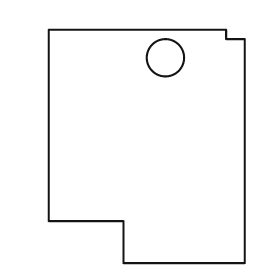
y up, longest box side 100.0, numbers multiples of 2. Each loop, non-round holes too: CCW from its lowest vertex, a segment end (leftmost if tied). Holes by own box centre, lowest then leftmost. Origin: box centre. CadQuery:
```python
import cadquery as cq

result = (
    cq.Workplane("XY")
    .moveTo(-10.0, -50.0)
    .lineTo(42.0, -50.0)
    .lineTo(42.0, 46.0)
    .lineTo(34.0, 46.0)
    .lineTo(34.0, 50.0)
    .lineTo(-42.0, 50.0)
    .lineTo(-42.0, -32.0)
    .lineTo(-10.0, -32.0)
    .close()
    .moveTo(8.0, 38.0)
    .circle(8.0)
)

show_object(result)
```